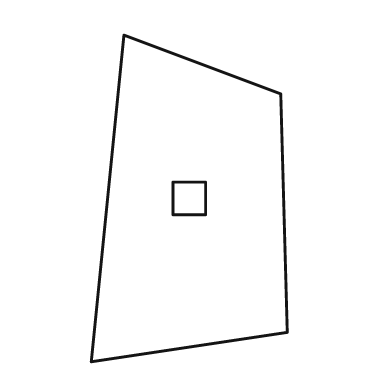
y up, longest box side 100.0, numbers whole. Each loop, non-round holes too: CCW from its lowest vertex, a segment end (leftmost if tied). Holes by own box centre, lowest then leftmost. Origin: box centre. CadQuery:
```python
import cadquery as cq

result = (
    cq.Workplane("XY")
    .moveTo(-30.0, -50.0)
    .lineTo(30.0, -41.0)
    .lineTo(28.0, 32.0)
    .lineTo(-20.0, 50.0)
    .close()
    .moveTo(-5.0, -5.0)
    .lineTo(5.0, -5.0)
    .lineTo(5.0, 5.0)
    .lineTo(-5.0, 5.0)
    .close()
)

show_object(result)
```